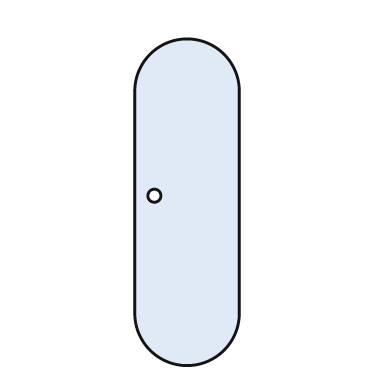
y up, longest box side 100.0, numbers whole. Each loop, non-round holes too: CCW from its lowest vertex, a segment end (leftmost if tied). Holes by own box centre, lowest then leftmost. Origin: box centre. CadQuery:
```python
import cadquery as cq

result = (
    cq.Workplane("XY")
    .moveTo(-16.0, -34.0)
    .threePointArc((0.0, -50.0), (16.0, -34.0))
    .lineTo(16.0, 34.0)
    .threePointArc((0.0, 50.0), (-16.0, 34.0))
    .close()
    .moveTo(-10.0, 2.0)
    .circle(2.0)
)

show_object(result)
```